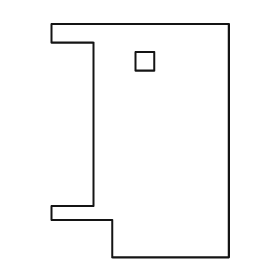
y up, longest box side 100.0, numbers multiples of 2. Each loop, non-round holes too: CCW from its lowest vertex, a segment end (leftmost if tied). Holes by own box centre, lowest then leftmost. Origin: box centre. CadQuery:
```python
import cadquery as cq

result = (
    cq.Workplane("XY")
    .moveTo(-12.0, -50.0)
    .lineTo(38.0, -50.0)
    .lineTo(38.0, 50.0)
    .lineTo(-38.0, 50.0)
    .lineTo(-38.0, 42.0)
    .lineTo(-20.0, 42.0)
    .lineTo(-20.0, -28.0)
    .lineTo(-38.0, -28.0)
    .lineTo(-38.0, -34.0)
    .lineTo(-12.0, -34.0)
    .close()
    .moveTo(-2.0, 30.0)
    .lineTo(6.0, 30.0)
    .lineTo(6.0, 38.0)
    .lineTo(-2.0, 38.0)
    .close()
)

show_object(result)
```